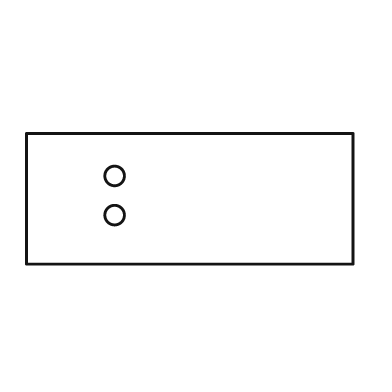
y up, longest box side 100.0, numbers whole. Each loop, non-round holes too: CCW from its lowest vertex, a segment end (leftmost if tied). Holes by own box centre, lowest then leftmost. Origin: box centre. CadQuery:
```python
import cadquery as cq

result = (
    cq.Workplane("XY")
    .moveTo(-50.0, -20.0)
    .lineTo(50.0, -20.0)
    .lineTo(50.0, 20.0)
    .lineTo(-50.0, 20.0)
    .close()
    .moveTo(-23.0, -5.0)
    .circle(3.0)
    .moveTo(-23.0, 7.0)
    .circle(3.0)
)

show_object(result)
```